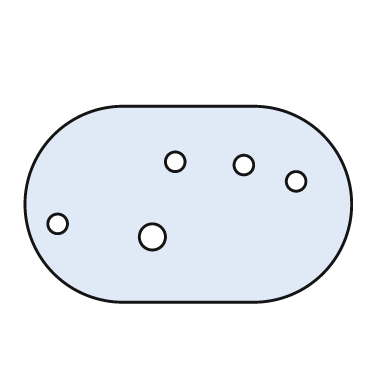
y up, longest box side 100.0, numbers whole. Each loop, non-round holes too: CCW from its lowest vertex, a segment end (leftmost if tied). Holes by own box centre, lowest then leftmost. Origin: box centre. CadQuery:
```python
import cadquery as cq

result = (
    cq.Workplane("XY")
    .moveTo(-20.0, -30.0)
    .lineTo(20.0, -30.0)
    .threePointArc((50.0, 0.0), (20.0, 30.0))
    .lineTo(-20.0, 30.0)
    .threePointArc((-50.0, 0.0), (-20.0, -30.0))
    .close()
    .moveTo(-11.0, -10.0)
    .circle(4.0)
    .moveTo(-40.0, -6.0)
    .circle(3.0)
    .moveTo(33.0, 7.0)
    .circle(3.0)
    .moveTo(17.0, 12.0)
    .circle(3.0)
    .moveTo(-4.0, 13.0)
    .circle(3.0)
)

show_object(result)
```